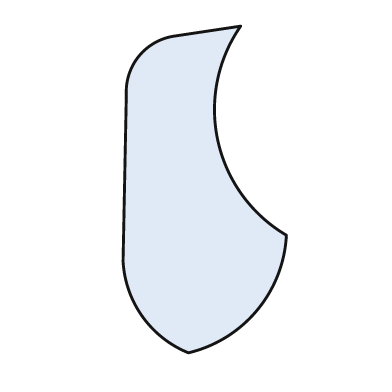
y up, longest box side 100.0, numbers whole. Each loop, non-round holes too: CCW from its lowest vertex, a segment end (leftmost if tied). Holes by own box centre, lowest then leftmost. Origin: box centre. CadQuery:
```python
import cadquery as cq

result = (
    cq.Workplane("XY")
    .moveTo(-5.0, -50.0)
    .threePointArc((16.0, -37.0), (25.0, -14.0))
    .threePointArc((4.0, 15.0), (11.0, 50.0))
    .lineTo(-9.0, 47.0)
    .threePointArc((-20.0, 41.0), (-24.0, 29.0))
    .lineTo(-25.0, -22.0)
    .threePointArc((-19.0, -39.0), (-5.0, -50.0))
    .close()
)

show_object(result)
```